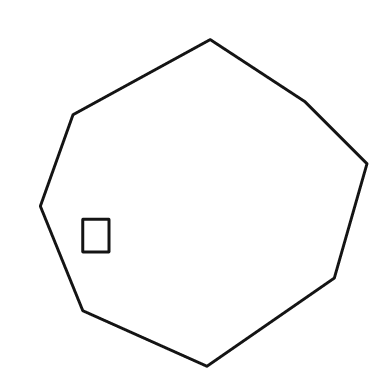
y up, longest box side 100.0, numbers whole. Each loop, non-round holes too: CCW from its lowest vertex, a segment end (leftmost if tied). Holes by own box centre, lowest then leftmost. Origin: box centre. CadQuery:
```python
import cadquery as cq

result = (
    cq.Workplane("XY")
    .moveTo(1.0, -50.0)
    .lineTo(40.0, -23.0)
    .lineTo(50.0, 12.0)
    .lineTo(31.0, 31.0)
    .lineTo(2.0, 50.0)
    .lineTo(-40.0, 27.0)
    .lineTo(-50.0, -1.0)
    .lineTo(-37.0, -33.0)
    .close()
    .moveTo(-37.0, -15.0)
    .lineTo(-29.0, -15.0)
    .lineTo(-29.0, -5.0)
    .lineTo(-37.0, -5.0)
    .close()
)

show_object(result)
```